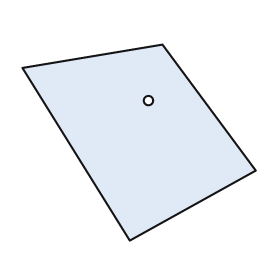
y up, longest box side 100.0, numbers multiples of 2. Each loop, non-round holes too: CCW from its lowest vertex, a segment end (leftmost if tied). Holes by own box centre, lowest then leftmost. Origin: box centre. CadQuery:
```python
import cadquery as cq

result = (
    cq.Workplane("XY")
    .moveTo(-4.0, -42.0)
    .lineTo(50.0, -12.0)
    .lineTo(10.0, 42.0)
    .lineTo(-50.0, 32.0)
    .close()
    .moveTo(4.0, 18.0)
    .circle(2.0)
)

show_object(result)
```